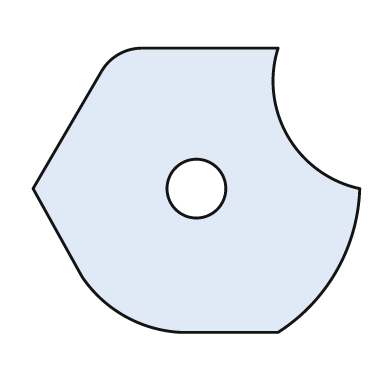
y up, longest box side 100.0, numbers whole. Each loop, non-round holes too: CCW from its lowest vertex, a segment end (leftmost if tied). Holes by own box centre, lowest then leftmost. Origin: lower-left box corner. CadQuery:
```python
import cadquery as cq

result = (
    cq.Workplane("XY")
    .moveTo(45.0, 0.0)
    .lineTo(75.0, 0.0)
    .threePointArc((93.0, 19.0), (100.0, 44.0))
    .threePointArc((78.0, 60.0), (75.0, 87.0))
    .lineTo(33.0, 87.0)
    .threePointArc((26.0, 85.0), (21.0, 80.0))
    .lineTo(0.0, 44.0)
    .lineTo(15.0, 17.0)
    .threePointArc((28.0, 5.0), (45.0, 0.0))
    .close()
    .moveTo(50.0, 44.0)
    .circle(9.0)
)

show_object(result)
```